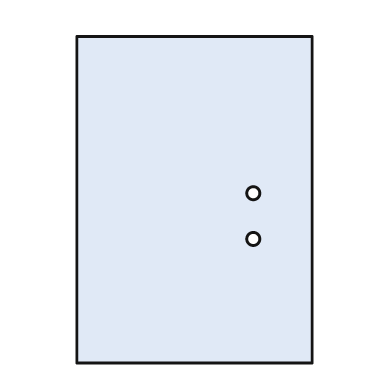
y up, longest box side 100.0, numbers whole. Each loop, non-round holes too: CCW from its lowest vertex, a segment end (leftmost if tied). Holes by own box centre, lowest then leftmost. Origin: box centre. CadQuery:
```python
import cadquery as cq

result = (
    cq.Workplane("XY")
    .moveTo(-36.0, -50.0)
    .lineTo(36.0, -50.0)
    .lineTo(36.0, 50.0)
    .lineTo(-36.0, 50.0)
    .close()
    .moveTo(18.0, -12.0)
    .circle(2.0)
    .moveTo(18.0, 2.0)
    .circle(2.0)
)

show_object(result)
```